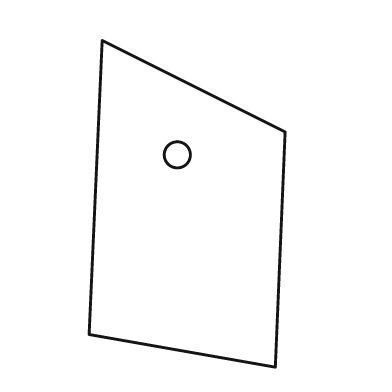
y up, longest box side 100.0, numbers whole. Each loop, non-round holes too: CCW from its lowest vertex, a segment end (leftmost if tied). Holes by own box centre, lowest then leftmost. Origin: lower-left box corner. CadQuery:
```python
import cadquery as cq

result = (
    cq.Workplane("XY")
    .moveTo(57.0, 0.0)
    .lineTo(60.0, 72.0)
    .lineTo(4.0, 100.0)
    .lineTo(0.0, 10.0)
    .close()
    .moveTo(27.0, 65.0)
    .circle(4.0)
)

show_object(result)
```